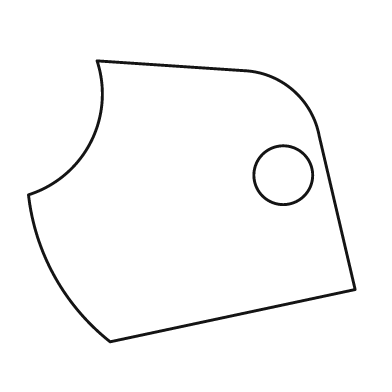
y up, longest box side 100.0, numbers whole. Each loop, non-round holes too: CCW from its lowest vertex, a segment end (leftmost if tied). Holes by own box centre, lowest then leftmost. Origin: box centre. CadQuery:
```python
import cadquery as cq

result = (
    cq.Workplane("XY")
    .moveTo(-25.0, -43.0)
    .lineTo(50.0, -27.0)
    .lineTo(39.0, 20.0)
    .threePointArc((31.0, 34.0), (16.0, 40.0))
    .lineTo(-29.0, 43.0)
    .threePointArc((-31.0, 18.0), (-50.0, 2.0))
    .threePointArc((-42.0, -23.0), (-25.0, -43.0))
    .close()
    .moveTo(28.0, 8.0)
    .circle(9.0)
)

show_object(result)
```